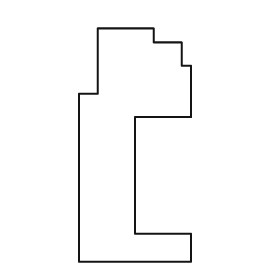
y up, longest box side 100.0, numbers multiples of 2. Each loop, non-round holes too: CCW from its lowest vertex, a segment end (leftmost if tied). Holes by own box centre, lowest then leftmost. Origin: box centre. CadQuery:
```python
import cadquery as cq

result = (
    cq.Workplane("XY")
    .moveTo(-24.0, -50.0)
    .lineTo(24.0, -50.0)
    .lineTo(24.0, -38.0)
    .lineTo(0.0, -38.0)
    .lineTo(0.0, 12.0)
    .lineTo(24.0, 12.0)
    .lineTo(24.0, 34.0)
    .lineTo(20.0, 34.0)
    .lineTo(20.0, 44.0)
    .lineTo(8.0, 44.0)
    .lineTo(8.0, 50.0)
    .lineTo(-16.0, 50.0)
    .lineTo(-16.0, 22.0)
    .lineTo(-24.0, 22.0)
    .close()
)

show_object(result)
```